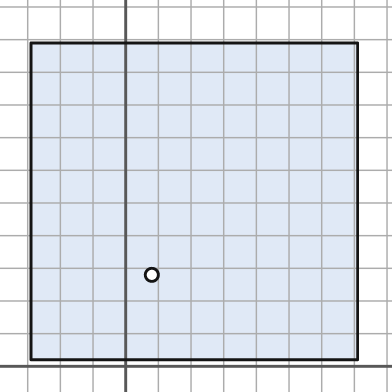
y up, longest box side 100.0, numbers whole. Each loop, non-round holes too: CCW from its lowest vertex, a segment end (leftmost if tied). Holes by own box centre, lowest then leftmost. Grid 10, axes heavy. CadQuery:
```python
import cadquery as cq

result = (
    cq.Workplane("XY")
    .moveTo(-29.0, 2.0)
    .lineTo(71.0, 2.0)
    .lineTo(71.0, 99.0)
    .lineTo(-29.0, 99.0)
    .close()
    .moveTo(8.0, 28.0)
    .circle(2.0)
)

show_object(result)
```